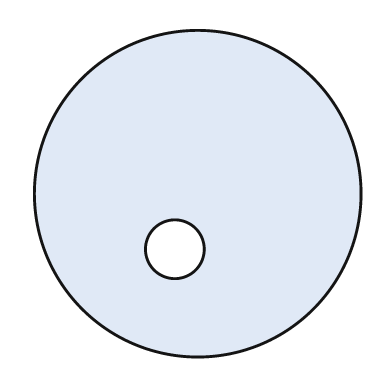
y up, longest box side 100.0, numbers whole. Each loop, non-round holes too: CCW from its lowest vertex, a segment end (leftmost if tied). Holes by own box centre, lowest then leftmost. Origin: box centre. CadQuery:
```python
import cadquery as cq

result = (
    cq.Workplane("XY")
    .moveTo(0.0, 0.0)
    .circle(50.0)
    .moveTo(-7.0, -17.0)
    .circle(9.0)
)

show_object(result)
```